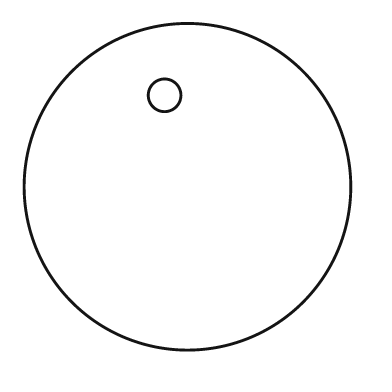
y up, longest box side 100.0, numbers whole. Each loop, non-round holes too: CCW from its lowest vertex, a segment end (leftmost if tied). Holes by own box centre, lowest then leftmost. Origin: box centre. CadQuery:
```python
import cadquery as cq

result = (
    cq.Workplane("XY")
    .moveTo(0.0, 0.0)
    .circle(50.0)
    .moveTo(-7.0, 28.0)
    .circle(5.0)
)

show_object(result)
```